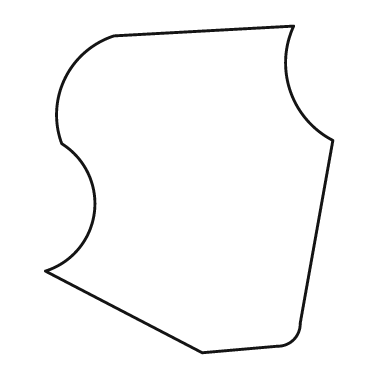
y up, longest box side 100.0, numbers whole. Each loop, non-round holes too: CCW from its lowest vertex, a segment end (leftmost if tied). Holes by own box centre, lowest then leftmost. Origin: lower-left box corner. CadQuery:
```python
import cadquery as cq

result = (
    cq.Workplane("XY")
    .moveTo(48.0, 0.0)
    .lineTo(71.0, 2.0)
    .threePointArc((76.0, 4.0), (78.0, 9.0))
    .lineTo(88.0, 65.0)
    .threePointArc((75.0, 80.0), (76.0, 100.0))
    .lineTo(21.0, 97.0)
    .threePointArc((6.0, 84.0), (5.0, 64.0))
    .threePointArc((15.0, 43.0), (0.0, 25.0))
    .close()
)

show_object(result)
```